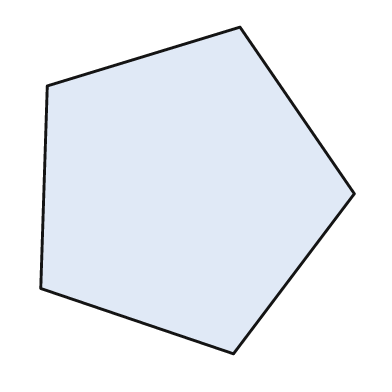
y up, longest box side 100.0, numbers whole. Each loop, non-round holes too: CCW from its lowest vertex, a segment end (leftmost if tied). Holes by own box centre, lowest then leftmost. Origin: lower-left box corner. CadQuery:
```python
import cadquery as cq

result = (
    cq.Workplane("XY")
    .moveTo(59.0, 0.0)
    .lineTo(96.0, 49.0)
    .lineTo(61.0, 100.0)
    .lineTo(2.0, 82.0)
    .lineTo(0.0, 20.0)
    .close()
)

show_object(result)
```